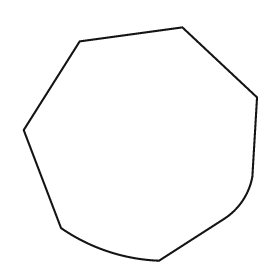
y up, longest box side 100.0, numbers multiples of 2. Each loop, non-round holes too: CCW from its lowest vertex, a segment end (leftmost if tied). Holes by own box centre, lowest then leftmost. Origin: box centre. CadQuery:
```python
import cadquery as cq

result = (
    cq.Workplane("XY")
    .moveTo(8.0, -50.0)
    .lineTo(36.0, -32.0)
    .threePointArc((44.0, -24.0), (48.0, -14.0))
    .lineTo(50.0, 20.0)
    .lineTo(18.0, 50.0)
    .lineTo(-26.0, 44.0)
    .lineTo(-50.0, 6.0)
    .lineTo(-34.0, -36.0)
    .threePointArc((-14.0, -46.0), (8.0, -50.0))
    .close()
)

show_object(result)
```